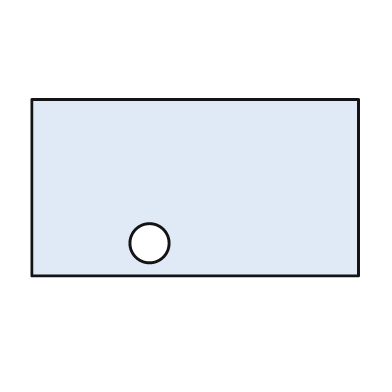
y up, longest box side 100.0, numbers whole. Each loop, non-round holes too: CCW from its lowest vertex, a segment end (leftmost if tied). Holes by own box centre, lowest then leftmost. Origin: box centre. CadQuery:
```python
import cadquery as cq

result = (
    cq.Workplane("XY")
    .moveTo(-50.0, -27.0)
    .lineTo(50.0, -27.0)
    .lineTo(50.0, 27.0)
    .lineTo(-50.0, 27.0)
    .close()
    .moveTo(-14.0, -17.0)
    .circle(6.0)
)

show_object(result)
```